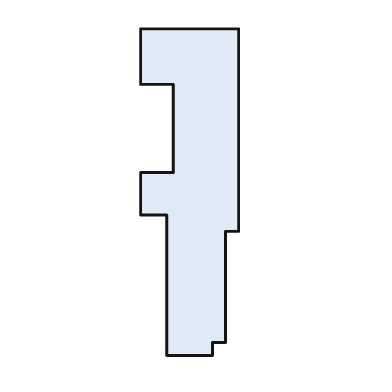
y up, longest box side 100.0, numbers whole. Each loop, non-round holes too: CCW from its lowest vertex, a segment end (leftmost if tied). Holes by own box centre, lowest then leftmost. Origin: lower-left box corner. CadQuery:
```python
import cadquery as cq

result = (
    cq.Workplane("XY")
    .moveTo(8.0, 0.0)
    .lineTo(22.0, 0.0)
    .lineTo(22.0, 4.0)
    .lineTo(26.0, 4.0)
    .lineTo(26.0, 38.0)
    .lineTo(30.0, 38.0)
    .lineTo(30.0, 100.0)
    .lineTo(0.0, 100.0)
    .lineTo(0.0, 83.0)
    .lineTo(10.0, 83.0)
    .lineTo(10.0, 56.0)
    .lineTo(0.0, 56.0)
    .lineTo(0.0, 43.0)
    .lineTo(8.0, 43.0)
    .close()
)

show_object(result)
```